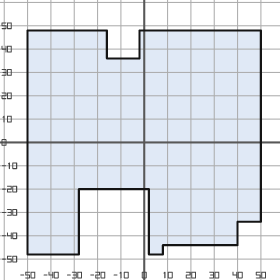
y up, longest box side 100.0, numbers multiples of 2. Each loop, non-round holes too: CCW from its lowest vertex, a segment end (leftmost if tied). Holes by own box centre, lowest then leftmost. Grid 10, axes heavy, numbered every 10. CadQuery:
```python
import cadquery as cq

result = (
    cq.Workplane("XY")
    .moveTo(-50.0, -48.0)
    .lineTo(-28.0, -48.0)
    .lineTo(-28.0, -20.0)
    .lineTo(2.0, -20.0)
    .lineTo(2.0, -48.0)
    .lineTo(8.0, -48.0)
    .lineTo(8.0, -44.0)
    .lineTo(40.0, -44.0)
    .lineTo(40.0, -34.0)
    .lineTo(50.0, -34.0)
    .lineTo(50.0, 48.0)
    .lineTo(-2.0, 48.0)
    .lineTo(-2.0, 36.0)
    .lineTo(-16.0, 36.0)
    .lineTo(-16.0, 48.0)
    .lineTo(-50.0, 48.0)
    .close()
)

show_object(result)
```